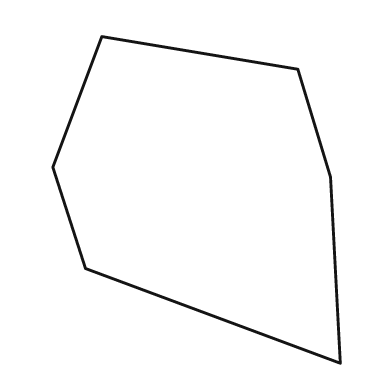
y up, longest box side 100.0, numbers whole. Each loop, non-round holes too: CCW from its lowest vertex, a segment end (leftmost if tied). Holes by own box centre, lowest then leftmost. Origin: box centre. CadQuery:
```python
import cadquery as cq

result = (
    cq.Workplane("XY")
    .moveTo(44.0, -50.0)
    .lineTo(41.0, 7.0)
    .lineTo(31.0, 40.0)
    .lineTo(-29.0, 50.0)
    .lineTo(-44.0, 10.0)
    .lineTo(-34.0, -21.0)
    .close()
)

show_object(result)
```